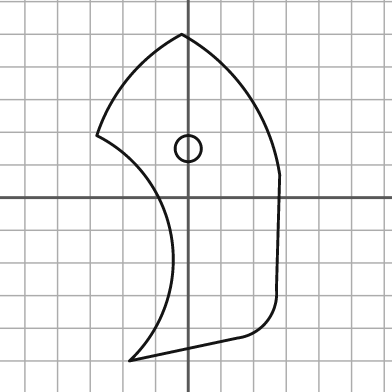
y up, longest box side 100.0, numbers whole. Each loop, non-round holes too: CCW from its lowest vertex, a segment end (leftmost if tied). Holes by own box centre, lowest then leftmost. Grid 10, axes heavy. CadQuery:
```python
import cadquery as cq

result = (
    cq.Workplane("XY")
    .moveTo(-18.0, -50.0)
    .lineTo(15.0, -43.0)
    .threePointArc((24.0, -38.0), (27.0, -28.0))
    .lineTo(28.0, 7.0)
    .threePointArc((18.0, 32.0), (-2.0, 50.0))
    .threePointArc((-18.0, 37.0), (-28.0, 19.0))
    .threePointArc((-5.0, -13.0), (-18.0, -50.0))
    .close()
    .moveTo(0.0, 15.0)
    .circle(4.0)
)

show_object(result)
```